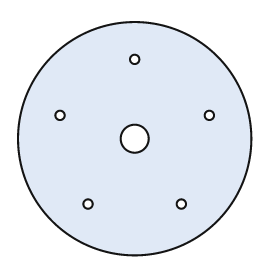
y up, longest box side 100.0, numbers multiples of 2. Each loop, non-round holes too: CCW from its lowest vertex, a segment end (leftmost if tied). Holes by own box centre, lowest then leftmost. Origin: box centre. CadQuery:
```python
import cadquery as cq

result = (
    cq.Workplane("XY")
    .moveTo(0.0, 0.0)
    .circle(50.0)
    .moveTo(-20.0, -28.0)
    .circle(2.0)
    .moveTo(20.0, -28.0)
    .circle(2.0)
    .moveTo(0.0, 0.0)
    .circle(6.0)
    .moveTo(-32.0, 10.0)
    .circle(2.0)
    .moveTo(32.0, 10.0)
    .circle(2.0)
    .moveTo(0.0, 34.0)
    .circle(2.0)
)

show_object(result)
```